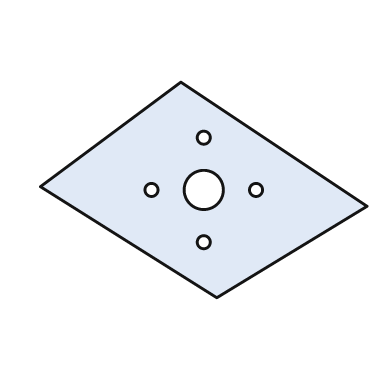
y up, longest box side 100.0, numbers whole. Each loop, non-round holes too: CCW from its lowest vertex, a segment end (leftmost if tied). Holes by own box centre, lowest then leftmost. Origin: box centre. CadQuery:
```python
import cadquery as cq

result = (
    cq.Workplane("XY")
    .moveTo(4.0, -33.0)
    .lineTo(50.0, -5.0)
    .lineTo(-7.0, 33.0)
    .lineTo(-50.0, 1.0)
    .close()
    .moveTo(0.0, -16.0)
    .circle(2.0)
    .moveTo(-16.0, 0.0)
    .circle(2.0)
    .moveTo(0.0, 0.0)
    .circle(6.0)
    .moveTo(16.0, 0.0)
    .circle(2.0)
    .moveTo(0.0, 16.0)
    .circle(2.0)
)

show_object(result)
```